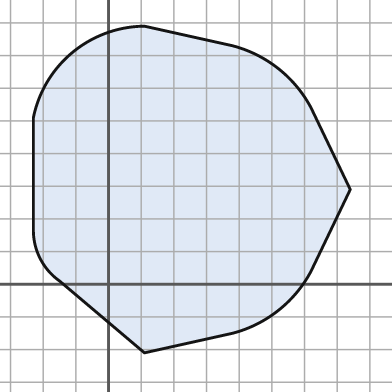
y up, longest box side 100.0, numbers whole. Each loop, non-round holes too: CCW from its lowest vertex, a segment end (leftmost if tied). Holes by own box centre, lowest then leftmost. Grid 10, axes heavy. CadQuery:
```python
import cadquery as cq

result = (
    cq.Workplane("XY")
    .moveTo(11.0, -21.0)
    .lineTo(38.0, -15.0)
    .threePointArc((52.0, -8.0), (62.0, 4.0))
    .lineTo(74.0, 29.0)
    .lineTo(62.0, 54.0)
    .threePointArc((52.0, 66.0), (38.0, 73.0))
    .lineTo(11.0, 79.0)
    .threePointArc((-11.0, 71.0), (-23.0, 51.0))
    .lineTo(-23.0, 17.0)
    .threePointArc((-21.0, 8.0), (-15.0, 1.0))
    .close()
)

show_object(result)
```